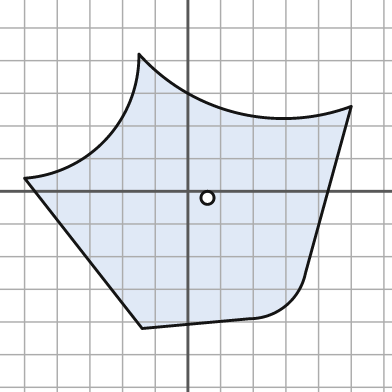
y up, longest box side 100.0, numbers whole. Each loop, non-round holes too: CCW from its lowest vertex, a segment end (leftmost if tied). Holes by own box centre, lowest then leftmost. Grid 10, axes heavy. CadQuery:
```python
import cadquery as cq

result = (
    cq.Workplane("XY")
    .moveTo(-14.0, -42.0)
    .lineTo(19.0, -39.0)
    .threePointArc((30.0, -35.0), (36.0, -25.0))
    .lineTo(50.0, 26.0)
    .threePointArc((15.0, 24.0), (-15.0, 42.0))
    .threePointArc((-25.0, 16.0), (-50.0, 4.0))
    .close()
    .moveTo(6.0, -2.0)
    .circle(2.0)
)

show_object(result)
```